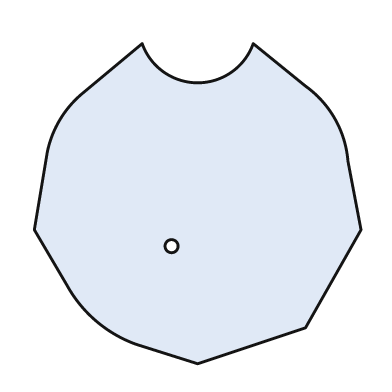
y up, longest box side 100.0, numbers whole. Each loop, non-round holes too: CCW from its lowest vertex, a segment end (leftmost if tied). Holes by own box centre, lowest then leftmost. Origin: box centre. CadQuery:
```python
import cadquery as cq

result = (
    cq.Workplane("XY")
    .moveTo(0.0, -49.0)
    .lineTo(33.0, -38.0)
    .lineTo(50.0, -8.0)
    .lineTo(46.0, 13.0)
    .threePointArc((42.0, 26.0), (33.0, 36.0))
    .lineTo(17.0, 49.0)
    .threePointArc((0.0, 37.0), (-17.0, 49.0))
    .lineTo(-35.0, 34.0)
    .threePointArc((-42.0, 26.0), (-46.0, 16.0))
    .lineTo(-50.0, -8.0)
    .lineTo(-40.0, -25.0)
    .threePointArc((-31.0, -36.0), (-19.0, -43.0))
    .close()
    .moveTo(-8.0, -13.0)
    .circle(2.0)
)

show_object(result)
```